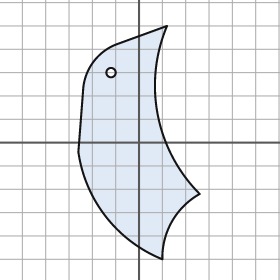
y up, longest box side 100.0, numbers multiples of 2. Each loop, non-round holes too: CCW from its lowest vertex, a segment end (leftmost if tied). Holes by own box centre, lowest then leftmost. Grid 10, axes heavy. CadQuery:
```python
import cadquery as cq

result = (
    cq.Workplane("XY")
    .moveTo(10.0, -50.0)
    .threePointArc((14.0, -34.0), (26.0, -22.0))
    .threePointArc((8.0, 12.0), (12.0, 50.0))
    .lineTo(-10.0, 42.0)
    .threePointArc((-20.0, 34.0), (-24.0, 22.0))
    .lineTo(-26.0, -4.0)
    .threePointArc((-14.0, -32.0), (10.0, -50.0))
    .close()
    .moveTo(-12.0, 30.0)
    .circle(2.0)
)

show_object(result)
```